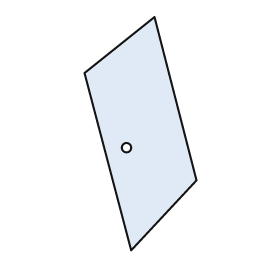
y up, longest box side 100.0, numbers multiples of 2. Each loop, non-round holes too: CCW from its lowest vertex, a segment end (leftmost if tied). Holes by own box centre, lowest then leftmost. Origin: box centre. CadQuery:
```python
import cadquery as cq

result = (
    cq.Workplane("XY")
    .moveTo(-4.0, -50.0)
    .lineTo(24.0, -20.0)
    .lineTo(6.0, 50.0)
    .lineTo(-24.0, 26.0)
    .close()
    .moveTo(-6.0, -6.0)
    .circle(2.0)
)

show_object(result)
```